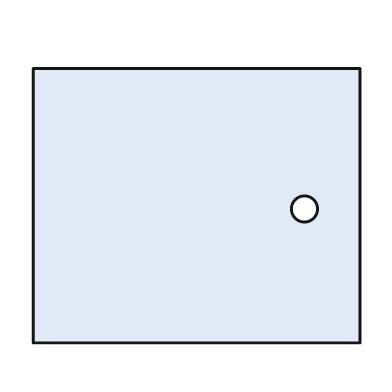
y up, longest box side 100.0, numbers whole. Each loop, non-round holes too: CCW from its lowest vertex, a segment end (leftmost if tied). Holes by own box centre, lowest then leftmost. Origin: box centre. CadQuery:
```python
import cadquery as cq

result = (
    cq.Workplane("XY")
    .moveTo(-50.0, -42.0)
    .lineTo(50.0, -42.0)
    .lineTo(50.0, 42.0)
    .lineTo(-50.0, 42.0)
    .close()
    .moveTo(33.0, -1.0)
    .circle(4.0)
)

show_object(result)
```